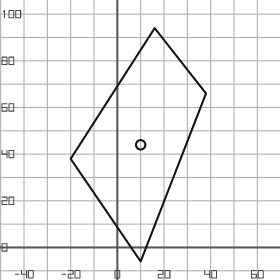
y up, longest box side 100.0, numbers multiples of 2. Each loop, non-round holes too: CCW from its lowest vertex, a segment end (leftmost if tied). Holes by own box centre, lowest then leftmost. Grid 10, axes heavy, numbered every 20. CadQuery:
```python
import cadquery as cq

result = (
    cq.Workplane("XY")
    .moveTo(10.0, -6.0)
    .lineTo(38.0, 66.0)
    .lineTo(16.0, 94.0)
    .lineTo(-20.0, 38.0)
    .close()
    .moveTo(10.0, 44.0)
    .circle(2.0)
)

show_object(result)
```